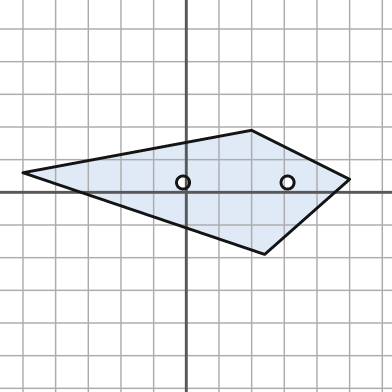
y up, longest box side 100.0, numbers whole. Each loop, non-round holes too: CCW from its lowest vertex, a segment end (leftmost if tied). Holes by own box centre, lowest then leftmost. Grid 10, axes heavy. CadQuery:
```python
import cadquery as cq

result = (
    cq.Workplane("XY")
    .moveTo(24.0, -19.0)
    .lineTo(50.0, 4.0)
    .lineTo(20.0, 19.0)
    .lineTo(-50.0, 6.0)
    .close()
    .moveTo(-1.0, 3.0)
    .circle(2.0)
    .moveTo(31.0, 3.0)
    .circle(2.0)
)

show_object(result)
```